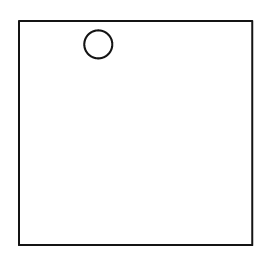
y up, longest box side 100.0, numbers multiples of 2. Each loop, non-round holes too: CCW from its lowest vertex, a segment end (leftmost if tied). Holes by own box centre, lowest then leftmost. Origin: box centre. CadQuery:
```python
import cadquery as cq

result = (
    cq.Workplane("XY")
    .moveTo(-50.0, -48.0)
    .lineTo(50.0, -48.0)
    .lineTo(50.0, 48.0)
    .lineTo(-50.0, 48.0)
    .close()
    .moveTo(-16.0, 38.0)
    .circle(6.0)
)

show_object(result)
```